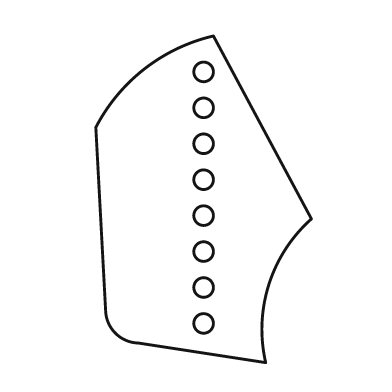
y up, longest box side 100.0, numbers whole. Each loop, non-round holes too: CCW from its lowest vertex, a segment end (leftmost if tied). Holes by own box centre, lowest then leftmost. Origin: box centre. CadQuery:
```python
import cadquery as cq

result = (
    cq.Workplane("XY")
    .moveTo(19.0, -50.0)
    .threePointArc((20.0, -26.0), (33.0, -6.0))
    .lineTo(3.0, 50.0)
    .threePointArc((-18.0, 40.0), (-33.0, 22.0))
    .lineTo(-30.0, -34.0)
    .threePointArc((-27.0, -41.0), (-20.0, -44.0))
    .close()
    .moveTo(0.0, -38.0)
    .circle(3.0)
    .moveTo(0.0, -27.0)
    .circle(3.0)
    .moveTo(0.0, -16.0)
    .circle(3.0)
    .moveTo(0.0, -5.0)
    .circle(3.0)
    .moveTo(0.0, 6.0)
    .circle(3.0)
    .moveTo(0.0, 17.0)
    .circle(3.0)
    .moveTo(0.0, 28.0)
    .circle(3.0)
    .moveTo(0.0, 39.0)
    .circle(3.0)
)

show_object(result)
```